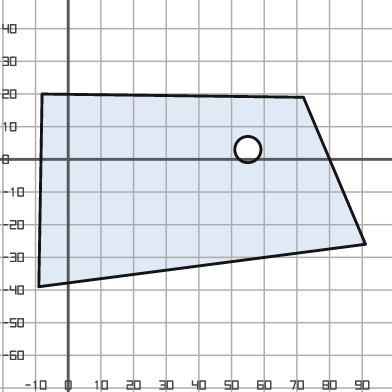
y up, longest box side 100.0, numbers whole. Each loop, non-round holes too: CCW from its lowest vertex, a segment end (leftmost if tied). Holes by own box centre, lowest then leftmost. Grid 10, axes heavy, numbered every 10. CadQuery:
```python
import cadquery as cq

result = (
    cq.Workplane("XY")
    .moveTo(-9.0, -39.0)
    .lineTo(91.0, -26.0)
    .lineTo(72.0, 19.0)
    .lineTo(-8.0, 20.0)
    .close()
    .moveTo(55.0, 3.0)
    .circle(4.0)
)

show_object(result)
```